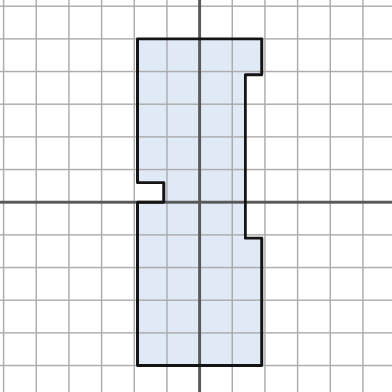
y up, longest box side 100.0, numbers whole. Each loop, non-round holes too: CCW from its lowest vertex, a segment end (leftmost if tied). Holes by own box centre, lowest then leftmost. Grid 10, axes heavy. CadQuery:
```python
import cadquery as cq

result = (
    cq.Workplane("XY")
    .moveTo(-19.0, -50.0)
    .lineTo(19.0, -50.0)
    .lineTo(19.0, -11.0)
    .lineTo(14.0, -11.0)
    .lineTo(14.0, 39.0)
    .lineTo(19.0, 39.0)
    .lineTo(19.0, 50.0)
    .lineTo(-19.0, 50.0)
    .lineTo(-19.0, 6.0)
    .lineTo(-11.0, 6.0)
    .lineTo(-11.0, 0.0)
    .lineTo(-19.0, 0.0)
    .close()
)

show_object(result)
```